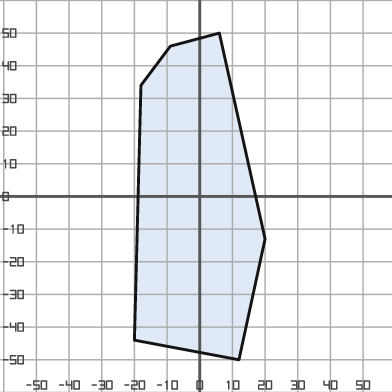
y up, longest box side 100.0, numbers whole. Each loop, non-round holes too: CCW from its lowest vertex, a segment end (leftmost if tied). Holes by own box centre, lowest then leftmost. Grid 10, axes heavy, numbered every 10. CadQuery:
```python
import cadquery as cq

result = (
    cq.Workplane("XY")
    .moveTo(12.0, -50.0)
    .lineTo(20.0, -13.0)
    .lineTo(6.0, 50.0)
    .lineTo(-9.0, 46.0)
    .lineTo(-18.0, 34.0)
    .lineTo(-20.0, -44.0)
    .close()
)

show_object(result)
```